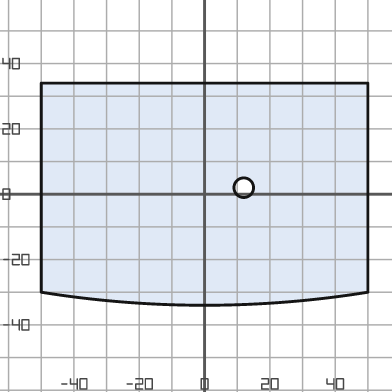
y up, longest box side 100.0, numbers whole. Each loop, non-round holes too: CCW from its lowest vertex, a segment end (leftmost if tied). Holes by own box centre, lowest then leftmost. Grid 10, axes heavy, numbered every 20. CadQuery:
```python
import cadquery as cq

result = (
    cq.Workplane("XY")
    .moveTo(-50.0, -30.0)
    .threePointArc((0.0, -34.0), (50.0, -30.0))
    .lineTo(50.0, 34.0)
    .lineTo(-50.0, 34.0)
    .close()
    .moveTo(12.0, 2.0)
    .circle(3.0)
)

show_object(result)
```